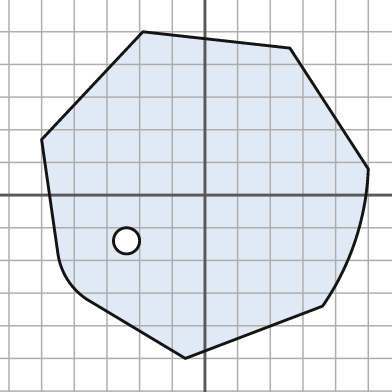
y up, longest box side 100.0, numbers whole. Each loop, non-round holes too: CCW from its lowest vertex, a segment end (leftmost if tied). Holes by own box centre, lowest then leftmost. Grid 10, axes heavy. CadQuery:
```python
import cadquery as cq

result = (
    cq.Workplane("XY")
    .moveTo(-6.0, -50.0)
    .lineTo(36.0, -34.0)
    .threePointArc((46.0, -14.0), (50.0, 8.0))
    .lineTo(26.0, 45.0)
    .lineTo(-19.0, 50.0)
    .lineTo(-50.0, 17.0)
    .lineTo(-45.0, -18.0)
    .threePointArc((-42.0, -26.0), (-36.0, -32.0))
    .close()
    .moveTo(-24.0, -14.0)
    .circle(4.0)
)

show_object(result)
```